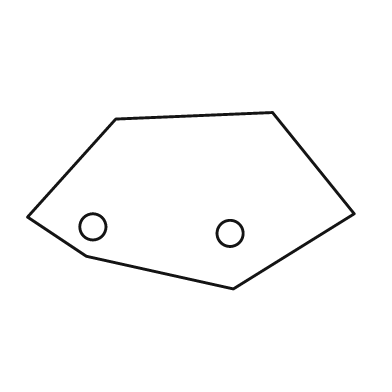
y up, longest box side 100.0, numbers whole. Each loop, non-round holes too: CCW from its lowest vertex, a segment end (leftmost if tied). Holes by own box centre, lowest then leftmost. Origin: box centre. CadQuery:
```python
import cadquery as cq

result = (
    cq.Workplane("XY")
    .moveTo(13.0, -27.0)
    .lineTo(50.0, -4.0)
    .lineTo(25.0, 27.0)
    .lineTo(-23.0, 25.0)
    .lineTo(-50.0, -5.0)
    .lineTo(-32.0, -17.0)
    .close()
    .moveTo(12.0, -10.0)
    .circle(4.0)
    .moveTo(-30.0, -8.0)
    .circle(4.0)
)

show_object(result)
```